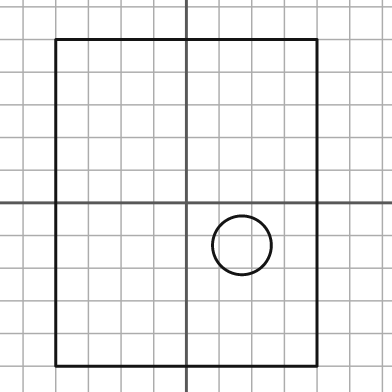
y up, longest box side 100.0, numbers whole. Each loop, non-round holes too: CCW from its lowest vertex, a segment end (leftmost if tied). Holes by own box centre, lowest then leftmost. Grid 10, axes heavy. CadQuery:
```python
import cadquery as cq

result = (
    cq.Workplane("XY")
    .moveTo(-40.0, -50.0)
    .lineTo(40.0, -50.0)
    .lineTo(40.0, 50.0)
    .lineTo(-40.0, 50.0)
    .close()
    .moveTo(17.0, -13.0)
    .circle(9.0)
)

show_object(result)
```